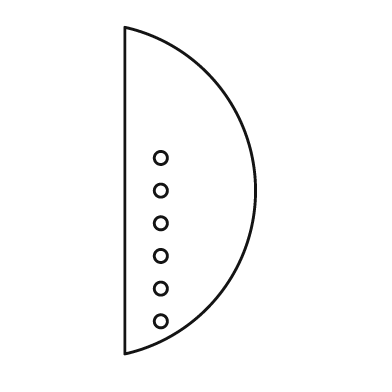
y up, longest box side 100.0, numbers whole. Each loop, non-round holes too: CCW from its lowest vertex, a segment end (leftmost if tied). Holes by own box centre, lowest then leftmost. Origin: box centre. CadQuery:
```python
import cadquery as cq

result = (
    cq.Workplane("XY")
    .moveTo(-20.0, -50.0)
    .threePointArc((20.0, 0.0), (-20.0, 50.0))
    .close()
    .moveTo(-9.0, -40.0)
    .circle(2.0)
    .moveTo(-9.0, -30.0)
    .circle(2.0)
    .moveTo(-9.0, -20.0)
    .circle(2.0)
    .moveTo(-9.0, -10.0)
    .circle(2.0)
    .moveTo(-9.0, 0.0)
    .circle(2.0)
    .moveTo(-9.0, 10.0)
    .circle(2.0)
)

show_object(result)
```